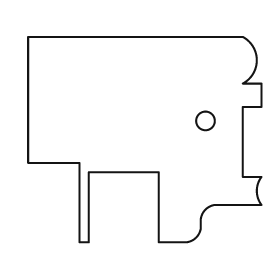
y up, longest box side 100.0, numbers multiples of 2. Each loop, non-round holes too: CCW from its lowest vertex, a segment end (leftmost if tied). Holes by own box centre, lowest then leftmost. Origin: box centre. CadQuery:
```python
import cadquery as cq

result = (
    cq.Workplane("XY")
    .moveTo(-28.0, -44.0)
    .lineTo(-24.0, -44.0)
    .lineTo(-24.0, -14.0)
    .lineTo(6.0, -14.0)
    .lineTo(6.0, -44.0)
    .lineTo(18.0, -44.0)
    .threePointArc((22.0, -42.0), (24.0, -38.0))
    .lineTo(24.0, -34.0)
    .threePointArc((26.0, -30.0), (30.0, -28.0))
    .lineTo(50.0, -28.0)
    .threePointArc((48.0, -22.0), (50.0, -16.0))
    .lineTo(42.0, -16.0)
    .lineTo(42.0, 14.0)
    .lineTo(50.0, 14.0)
    .lineTo(50.0, 24.0)
    .lineTo(42.0, 24.0)
    .threePointArc((48.0, 34.0), (42.0, 44.0))
    .lineTo(-50.0, 44.0)
    .lineTo(-50.0, -10.0)
    .lineTo(-28.0, -10.0)
    .close()
    .moveTo(26.0, 8.0)
    .circle(4.0)
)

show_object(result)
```